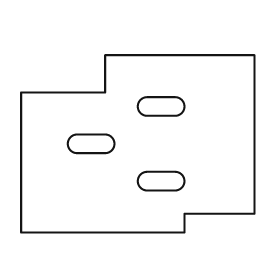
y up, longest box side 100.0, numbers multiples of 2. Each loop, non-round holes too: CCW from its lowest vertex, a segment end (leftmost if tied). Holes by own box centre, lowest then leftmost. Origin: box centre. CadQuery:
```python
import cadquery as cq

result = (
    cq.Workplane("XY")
    .moveTo(-50.0, -38.0)
    .lineTo(20.0, -38.0)
    .lineTo(20.0, -30.0)
    .lineTo(50.0, -30.0)
    .lineTo(50.0, 38.0)
    .lineTo(-14.0, 38.0)
    .lineTo(-14.0, 22.0)
    .lineTo(-50.0, 22.0)
    .close()
    .moveTo(4.0, -20.0)
    .lineTo(16.0, -20.0)
    .threePointArc((20.0, -16.0), (16.0, -12.0))
    .lineTo(4.0, -12.0)
    .threePointArc((0.0, -16.0), (4.0, -20.0))
    .close()
    .moveTo(-26.0, -4.0)
    .lineTo(-14.0, -4.0)
    .threePointArc((-10.0, 0.0), (-14.0, 4.0))
    .lineTo(-26.0, 4.0)
    .threePointArc((-30.0, 0.0), (-26.0, -4.0))
    .close()
    .moveTo(4.0, 12.0)
    .lineTo(16.0, 12.0)
    .threePointArc((20.0, 16.0), (16.0, 20.0))
    .lineTo(4.0, 20.0)
    .threePointArc((0.0, 16.0), (4.0, 12.0))
    .close()
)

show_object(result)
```